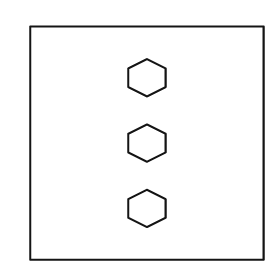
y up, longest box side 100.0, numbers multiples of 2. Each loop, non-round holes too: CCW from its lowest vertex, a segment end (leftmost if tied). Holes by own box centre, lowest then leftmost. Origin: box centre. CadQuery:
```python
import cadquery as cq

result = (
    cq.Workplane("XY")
    .moveTo(-50.0, -50.0)
    .lineTo(50.0, -50.0)
    .lineTo(50.0, 50.0)
    .lineTo(-50.0, 50.0)
    .close()
    .moveTo(0.0, -36.0)
    .lineTo(8.0, -32.0)
    .lineTo(8.0, -24.0)
    .lineTo(0.0, -20.0)
    .lineTo(-8.0, -24.0)
    .lineTo(-8.0, -32.0)
    .close()
    .moveTo(0.0, -8.0)
    .lineTo(8.0, -4.0)
    .lineTo(8.0, 4.0)
    .lineTo(0.0, 8.0)
    .lineTo(-8.0, 4.0)
    .lineTo(-8.0, -4.0)
    .close()
    .moveTo(0.0, 20.0)
    .lineTo(8.0, 24.0)
    .lineTo(8.0, 32.0)
    .lineTo(0.0, 36.0)
    .lineTo(-8.0, 32.0)
    .lineTo(-8.0, 24.0)
    .close()
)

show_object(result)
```